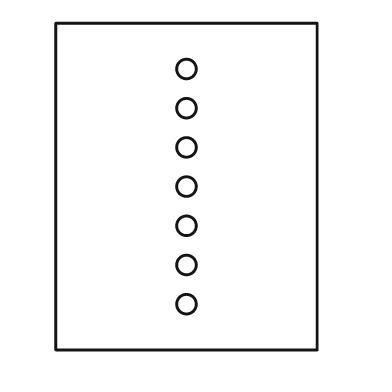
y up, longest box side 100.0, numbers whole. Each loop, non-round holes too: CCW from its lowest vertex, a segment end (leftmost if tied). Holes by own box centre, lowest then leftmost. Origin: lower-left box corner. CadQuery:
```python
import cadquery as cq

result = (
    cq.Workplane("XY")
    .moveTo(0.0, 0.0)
    .lineTo(80.0, 0.0)
    .lineTo(80.0, 100.0)
    .lineTo(0.0, 100.0)
    .close()
    .moveTo(40.0, 14.0)
    .circle(3.0)
    .moveTo(40.0, 26.0)
    .circle(3.0)
    .moveTo(40.0, 38.0)
    .circle(3.0)
    .moveTo(40.0, 50.0)
    .circle(3.0)
    .moveTo(40.0, 62.0)
    .circle(3.0)
    .moveTo(40.0, 74.0)
    .circle(3.0)
    .moveTo(40.0, 86.0)
    .circle(3.0)
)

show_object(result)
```